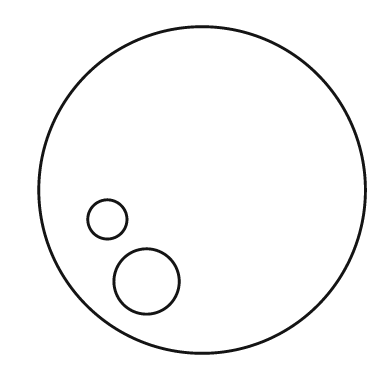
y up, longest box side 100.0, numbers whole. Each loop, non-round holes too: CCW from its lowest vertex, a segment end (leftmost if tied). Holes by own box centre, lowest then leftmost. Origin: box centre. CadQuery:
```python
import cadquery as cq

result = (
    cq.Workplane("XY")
    .moveTo(0.0, 0.0)
    .circle(50.0)
    .moveTo(-17.0, -28.0)
    .circle(10.0)
    .moveTo(-29.0, -9.0)
    .circle(6.0)
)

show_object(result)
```